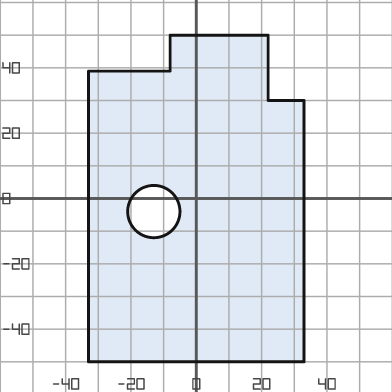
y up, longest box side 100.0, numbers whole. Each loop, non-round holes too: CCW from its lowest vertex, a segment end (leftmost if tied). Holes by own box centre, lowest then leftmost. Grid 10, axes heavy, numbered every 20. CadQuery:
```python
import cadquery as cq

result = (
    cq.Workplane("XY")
    .moveTo(-33.0, -50.0)
    .lineTo(33.0, -50.0)
    .lineTo(33.0, 30.0)
    .lineTo(22.0, 30.0)
    .lineTo(22.0, 50.0)
    .lineTo(-8.0, 50.0)
    .lineTo(-8.0, 39.0)
    .lineTo(-33.0, 39.0)
    .close()
    .moveTo(-13.0, -4.0)
    .circle(8.0)
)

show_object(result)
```